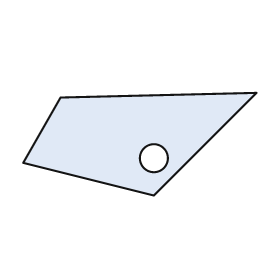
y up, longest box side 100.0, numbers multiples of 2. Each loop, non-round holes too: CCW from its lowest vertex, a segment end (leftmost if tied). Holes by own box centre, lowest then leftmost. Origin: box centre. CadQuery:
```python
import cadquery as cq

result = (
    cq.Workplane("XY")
    .moveTo(6.0, -22.0)
    .lineTo(50.0, 22.0)
    .lineTo(-34.0, 20.0)
    .lineTo(-50.0, -8.0)
    .close()
    .moveTo(6.0, -6.0)
    .circle(6.0)
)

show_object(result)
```